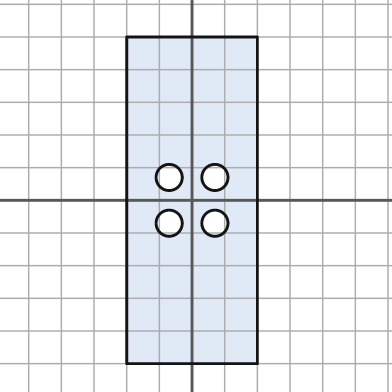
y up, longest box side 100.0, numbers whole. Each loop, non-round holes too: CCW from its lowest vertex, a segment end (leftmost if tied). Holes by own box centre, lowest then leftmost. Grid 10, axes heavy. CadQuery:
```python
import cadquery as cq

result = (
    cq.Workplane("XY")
    .moveTo(-20.0, -50.0)
    .lineTo(20.0, -50.0)
    .lineTo(20.0, 50.0)
    .lineTo(-20.0, 50.0)
    .close()
    .moveTo(-7.0, -7.0)
    .circle(4.0)
    .moveTo(7.0, -7.0)
    .circle(4.0)
    .moveTo(-7.0, 7.0)
    .circle(4.0)
    .moveTo(7.0, 7.0)
    .circle(4.0)
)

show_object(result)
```